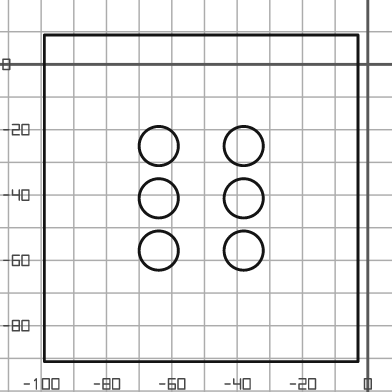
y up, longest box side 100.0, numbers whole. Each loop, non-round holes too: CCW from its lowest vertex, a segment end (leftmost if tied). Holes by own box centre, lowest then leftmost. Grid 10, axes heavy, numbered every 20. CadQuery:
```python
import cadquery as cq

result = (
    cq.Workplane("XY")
    .moveTo(-99.0, -91.0)
    .lineTo(-3.0, -91.0)
    .lineTo(-3.0, 9.0)
    .lineTo(-99.0, 9.0)
    .close()
    .moveTo(-64.0, -57.0)
    .circle(6.0)
    .moveTo(-38.0, -57.0)
    .circle(6.0)
    .moveTo(-64.0, -41.0)
    .circle(6.0)
    .moveTo(-38.0, -41.0)
    .circle(6.0)
    .moveTo(-64.0, -25.0)
    .circle(6.0)
    .moveTo(-38.0, -25.0)
    .circle(6.0)
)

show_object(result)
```